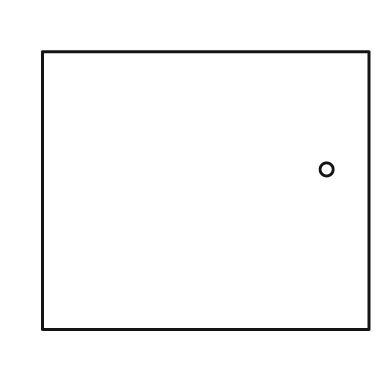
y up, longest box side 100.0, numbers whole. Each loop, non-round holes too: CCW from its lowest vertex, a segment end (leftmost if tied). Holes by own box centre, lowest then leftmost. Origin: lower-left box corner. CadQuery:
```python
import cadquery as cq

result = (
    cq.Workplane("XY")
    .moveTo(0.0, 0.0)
    .lineTo(100.0, 0.0)
    .lineTo(100.0, 85.0)
    .lineTo(0.0, 85.0)
    .close()
    .moveTo(87.0, 49.0)
    .circle(2.0)
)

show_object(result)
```